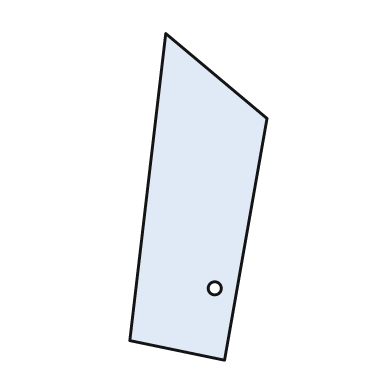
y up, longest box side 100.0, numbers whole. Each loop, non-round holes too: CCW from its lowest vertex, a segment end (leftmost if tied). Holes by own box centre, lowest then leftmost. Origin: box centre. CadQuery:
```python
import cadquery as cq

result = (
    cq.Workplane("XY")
    .moveTo(8.0, -50.0)
    .lineTo(21.0, 24.0)
    .lineTo(-10.0, 50.0)
    .lineTo(-21.0, -44.0)
    .close()
    .moveTo(5.0, -28.0)
    .circle(2.0)
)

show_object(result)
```